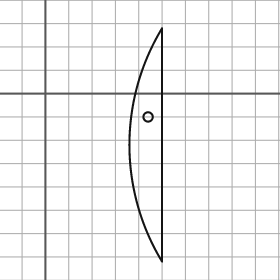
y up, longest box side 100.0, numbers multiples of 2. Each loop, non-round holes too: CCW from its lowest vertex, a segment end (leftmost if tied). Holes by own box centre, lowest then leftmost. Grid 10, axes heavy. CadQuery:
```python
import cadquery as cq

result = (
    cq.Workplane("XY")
    .moveTo(50.0, -72.0)
    .lineTo(50.0, 28.0)
    .threePointArc((36.0, -22.0), (50.0, -72.0))
    .close()
    .moveTo(44.0, -10.0)
    .circle(2.0)
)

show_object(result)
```